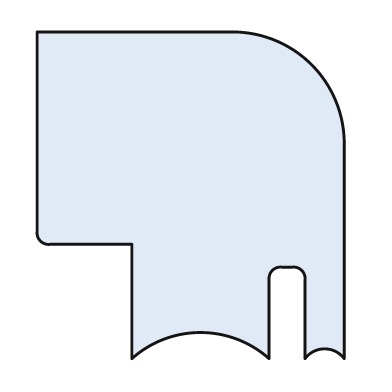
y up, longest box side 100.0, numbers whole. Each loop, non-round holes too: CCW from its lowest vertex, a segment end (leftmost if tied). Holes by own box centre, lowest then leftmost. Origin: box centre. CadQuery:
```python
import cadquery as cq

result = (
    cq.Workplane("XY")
    .moveTo(-18.0, -50.0)
    .threePointArc((3.0, -42.0), (24.0, -50.0))
    .lineTo(24.0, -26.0)
    .threePointArc((25.0, -23.0), (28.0, -22.0))
    .lineTo(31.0, -22.0)
    .threePointArc((34.0, -23.0), (35.0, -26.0))
    .lineTo(35.0, -50.0)
    .threePointArc((41.0, -47.0), (47.0, -50.0))
    .lineTo(47.0, 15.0)
    .threePointArc((37.0, 40.0), (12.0, 50.0))
    .lineTo(-47.0, 50.0)
    .lineTo(-47.0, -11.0)
    .threePointArc((-46.0, -14.0), (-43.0, -15.0))
    .lineTo(-18.0, -15.0)
    .close()
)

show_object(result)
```